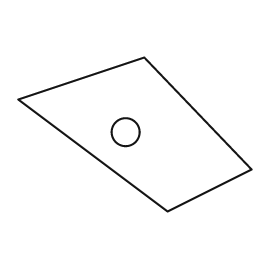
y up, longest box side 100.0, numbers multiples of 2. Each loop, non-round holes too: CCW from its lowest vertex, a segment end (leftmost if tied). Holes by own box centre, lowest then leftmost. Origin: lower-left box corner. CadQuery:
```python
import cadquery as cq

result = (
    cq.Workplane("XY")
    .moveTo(64.0, 0.0)
    .lineTo(100.0, 18.0)
    .lineTo(54.0, 66.0)
    .lineTo(0.0, 48.0)
    .close()
    .moveTo(46.0, 34.0)
    .circle(6.0)
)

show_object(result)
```